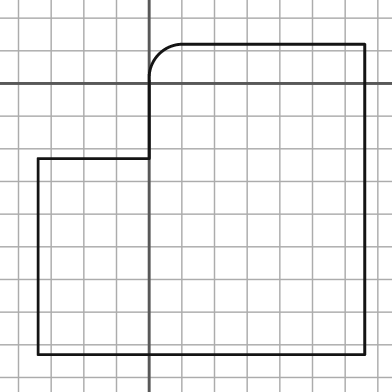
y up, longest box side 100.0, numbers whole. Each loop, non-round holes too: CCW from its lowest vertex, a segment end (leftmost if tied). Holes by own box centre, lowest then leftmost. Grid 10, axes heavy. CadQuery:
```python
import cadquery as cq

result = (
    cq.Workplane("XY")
    .moveTo(-34.0, -83.0)
    .lineTo(66.0, -83.0)
    .lineTo(66.0, 12.0)
    .lineTo(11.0, 12.0)
    .threePointArc((3.0, 9.0), (0.0, 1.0))
    .lineTo(0.0, -23.0)
    .lineTo(-34.0, -23.0)
    .close()
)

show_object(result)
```